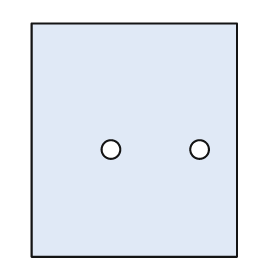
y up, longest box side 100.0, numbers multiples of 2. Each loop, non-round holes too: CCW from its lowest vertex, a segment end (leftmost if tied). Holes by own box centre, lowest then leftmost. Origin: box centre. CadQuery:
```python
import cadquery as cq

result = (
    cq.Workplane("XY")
    .moveTo(-44.0, -50.0)
    .lineTo(44.0, -50.0)
    .lineTo(44.0, 50.0)
    .lineTo(-44.0, 50.0)
    .close()
    .moveTo(-10.0, -4.0)
    .circle(4.0)
    .moveTo(28.0, -4.0)
    .circle(4.0)
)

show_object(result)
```